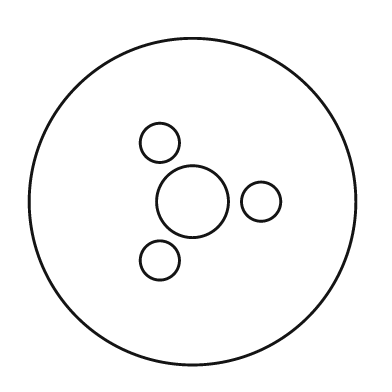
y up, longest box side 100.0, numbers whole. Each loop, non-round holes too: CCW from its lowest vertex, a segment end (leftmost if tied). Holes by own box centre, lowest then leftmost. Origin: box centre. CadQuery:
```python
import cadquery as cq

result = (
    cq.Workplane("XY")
    .moveTo(0.0, 0.0)
    .circle(50.0)
    .moveTo(-10.0, -18.0)
    .circle(6.0)
    .moveTo(0.0, 0.0)
    .circle(11.0)
    .moveTo(21.0, 0.0)
    .circle(6.0)
    .moveTo(-10.0, 18.0)
    .circle(6.0)
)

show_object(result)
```